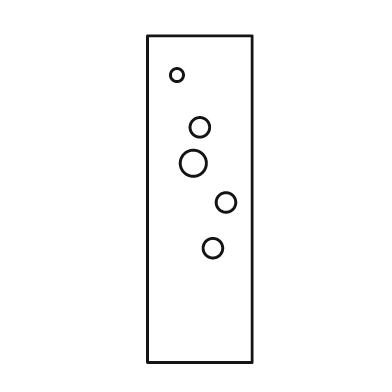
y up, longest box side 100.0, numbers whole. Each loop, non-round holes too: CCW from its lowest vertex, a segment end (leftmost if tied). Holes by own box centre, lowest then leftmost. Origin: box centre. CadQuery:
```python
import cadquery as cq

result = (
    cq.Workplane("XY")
    .moveTo(-16.0, -50.0)
    .lineTo(16.0, -50.0)
    .lineTo(16.0, 50.0)
    .lineTo(-16.0, 50.0)
    .close()
    .moveTo(4.0, -15.0)
    .circle(3.0)
    .moveTo(8.0, -1.0)
    .circle(3.0)
    .moveTo(-2.0, 11.0)
    .circle(4.0)
    .moveTo(0.0, 22.0)
    .circle(3.0)
    .moveTo(-7.0, 38.0)
    .circle(2.0)
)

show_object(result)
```